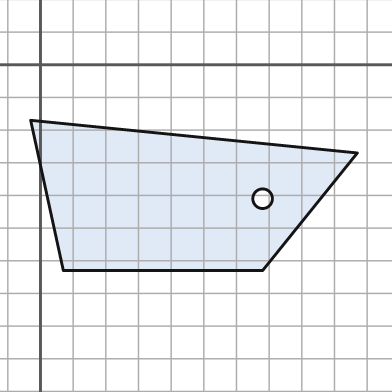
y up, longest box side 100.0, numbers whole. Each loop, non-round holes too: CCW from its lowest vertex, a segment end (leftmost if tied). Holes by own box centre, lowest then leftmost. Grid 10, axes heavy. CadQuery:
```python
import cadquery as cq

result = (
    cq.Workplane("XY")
    .moveTo(7.0, -63.0)
    .lineTo(68.0, -63.0)
    .lineTo(97.0, -27.0)
    .lineTo(-3.0, -17.0)
    .close()
    .moveTo(68.0, -41.0)
    .circle(3.0)
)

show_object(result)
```